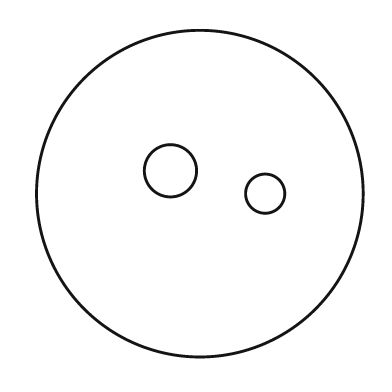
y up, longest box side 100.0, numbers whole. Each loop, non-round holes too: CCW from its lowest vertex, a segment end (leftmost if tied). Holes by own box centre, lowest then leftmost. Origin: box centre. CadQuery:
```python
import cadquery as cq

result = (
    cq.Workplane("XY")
    .moveTo(0.0, 0.0)
    .circle(50.0)
    .moveTo(20.0, 0.0)
    .circle(6.0)
    .moveTo(-9.0, 7.0)
    .circle(8.0)
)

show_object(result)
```